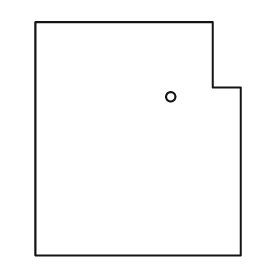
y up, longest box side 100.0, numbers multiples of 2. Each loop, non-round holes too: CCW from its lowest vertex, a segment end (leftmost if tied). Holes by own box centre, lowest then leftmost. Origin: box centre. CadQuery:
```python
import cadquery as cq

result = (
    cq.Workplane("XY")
    .moveTo(-44.0, -50.0)
    .lineTo(44.0, -50.0)
    .lineTo(44.0, 22.0)
    .lineTo(32.0, 22.0)
    .lineTo(32.0, 50.0)
    .lineTo(-44.0, 50.0)
    .close()
    .moveTo(14.0, 18.0)
    .circle(2.0)
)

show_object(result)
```